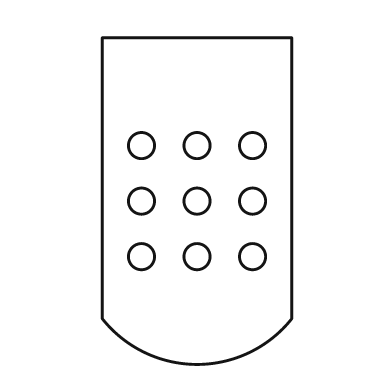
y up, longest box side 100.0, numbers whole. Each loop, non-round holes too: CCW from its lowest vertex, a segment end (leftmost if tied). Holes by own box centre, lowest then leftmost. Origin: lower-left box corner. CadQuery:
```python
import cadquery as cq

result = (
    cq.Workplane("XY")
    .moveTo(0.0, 14.0)
    .threePointArc((29.0, 0.0), (58.0, 14.0))
    .lineTo(58.0, 100.0)
    .lineTo(0.0, 100.0)
    .close()
    .moveTo(12.0, 33.0)
    .circle(4.0)
    .moveTo(29.0, 33.0)
    .circle(4.0)
    .moveTo(46.0, 33.0)
    .circle(4.0)
    .moveTo(12.0, 50.0)
    .circle(4.0)
    .moveTo(29.0, 50.0)
    .circle(4.0)
    .moveTo(46.0, 50.0)
    .circle(4.0)
    .moveTo(12.0, 67.0)
    .circle(4.0)
    .moveTo(29.0, 67.0)
    .circle(4.0)
    .moveTo(46.0, 67.0)
    .circle(4.0)
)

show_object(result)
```